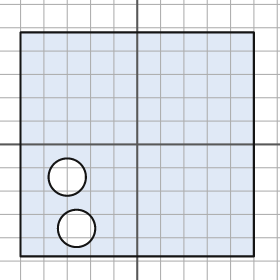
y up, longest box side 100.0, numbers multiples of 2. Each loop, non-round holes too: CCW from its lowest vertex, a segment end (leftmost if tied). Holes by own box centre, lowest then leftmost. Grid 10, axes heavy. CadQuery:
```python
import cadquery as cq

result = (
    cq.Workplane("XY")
    .moveTo(-50.0, -48.0)
    .lineTo(50.0, -48.0)
    .lineTo(50.0, 48.0)
    .lineTo(-50.0, 48.0)
    .close()
    .moveTo(-26.0, -36.0)
    .circle(8.0)
    .moveTo(-30.0, -14.0)
    .circle(8.0)
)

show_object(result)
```